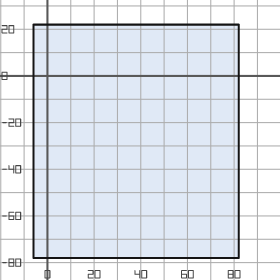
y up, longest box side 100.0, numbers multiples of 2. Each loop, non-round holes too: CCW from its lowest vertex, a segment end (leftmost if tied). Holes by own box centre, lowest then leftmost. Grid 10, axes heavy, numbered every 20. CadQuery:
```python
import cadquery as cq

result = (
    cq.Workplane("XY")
    .moveTo(-6.0, -78.0)
    .lineTo(82.0, -78.0)
    .lineTo(82.0, 22.0)
    .lineTo(-6.0, 22.0)
    .close()
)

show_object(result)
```